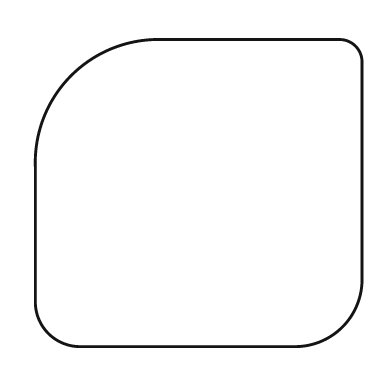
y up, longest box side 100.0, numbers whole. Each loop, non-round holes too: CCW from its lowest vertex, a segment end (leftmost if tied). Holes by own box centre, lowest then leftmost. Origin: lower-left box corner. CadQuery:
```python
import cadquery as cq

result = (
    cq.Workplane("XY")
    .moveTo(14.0, 0.0)
    .lineTo(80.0, 0.0)
    .threePointArc((94.0, 6.0), (100.0, 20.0))
    .lineTo(100.0, 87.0)
    .threePointArc((98.0, 92.0), (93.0, 94.0))
    .lineTo(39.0, 94.0)
    .threePointArc((11.0, 83.0), (0.0, 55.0))
    .lineTo(0.0, 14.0)
    .threePointArc((4.0, 4.0), (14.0, 0.0))
    .close()
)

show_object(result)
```